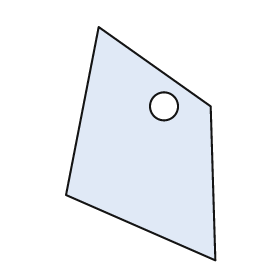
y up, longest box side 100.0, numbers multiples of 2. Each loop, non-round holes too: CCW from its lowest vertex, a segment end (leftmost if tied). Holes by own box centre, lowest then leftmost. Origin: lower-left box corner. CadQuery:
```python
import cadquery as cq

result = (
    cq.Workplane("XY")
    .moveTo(64.0, 0.0)
    .lineTo(62.0, 66.0)
    .lineTo(14.0, 100.0)
    .lineTo(0.0, 28.0)
    .close()
    .moveTo(42.0, 66.0)
    .circle(6.0)
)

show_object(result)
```